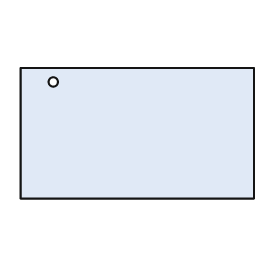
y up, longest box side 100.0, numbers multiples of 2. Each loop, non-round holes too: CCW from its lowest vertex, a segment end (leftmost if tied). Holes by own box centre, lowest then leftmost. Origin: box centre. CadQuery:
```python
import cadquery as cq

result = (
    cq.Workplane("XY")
    .moveTo(-50.0, -28.0)
    .lineTo(50.0, -28.0)
    .lineTo(50.0, 28.0)
    .lineTo(-50.0, 28.0)
    .close()
    .moveTo(-36.0, 22.0)
    .circle(2.0)
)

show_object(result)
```